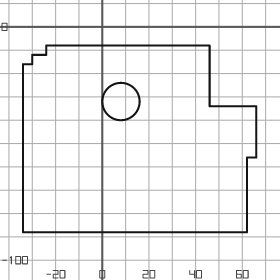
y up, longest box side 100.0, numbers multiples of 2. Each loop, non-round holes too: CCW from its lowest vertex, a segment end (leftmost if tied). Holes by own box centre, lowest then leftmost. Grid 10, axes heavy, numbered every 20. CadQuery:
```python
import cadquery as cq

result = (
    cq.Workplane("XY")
    .moveTo(-34.0, -88.0)
    .lineTo(62.0, -88.0)
    .lineTo(62.0, -56.0)
    .lineTo(66.0, -56.0)
    .lineTo(66.0, -34.0)
    .lineTo(46.0, -34.0)
    .lineTo(46.0, -8.0)
    .lineTo(-24.0, -8.0)
    .lineTo(-24.0, -12.0)
    .lineTo(-30.0, -12.0)
    .lineTo(-30.0, -16.0)
    .lineTo(-34.0, -16.0)
    .close()
    .moveTo(8.0, -32.0)
    .circle(8.0)
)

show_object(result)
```